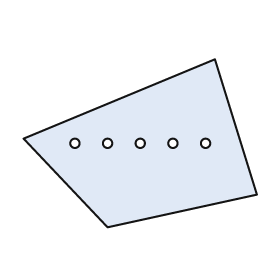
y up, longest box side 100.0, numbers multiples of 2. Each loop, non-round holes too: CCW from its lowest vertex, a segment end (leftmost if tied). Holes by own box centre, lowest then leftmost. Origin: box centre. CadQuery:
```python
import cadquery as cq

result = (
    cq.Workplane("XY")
    .moveTo(-14.0, -36.0)
    .lineTo(50.0, -22.0)
    .lineTo(32.0, 36.0)
    .lineTo(-50.0, 2.0)
    .close()
    .moveTo(-28.0, 0.0)
    .circle(2.0)
    .moveTo(-14.0, 0.0)
    .circle(2.0)
    .moveTo(0.0, 0.0)
    .circle(2.0)
    .moveTo(14.0, 0.0)
    .circle(2.0)
    .moveTo(28.0, 0.0)
    .circle(2.0)
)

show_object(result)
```